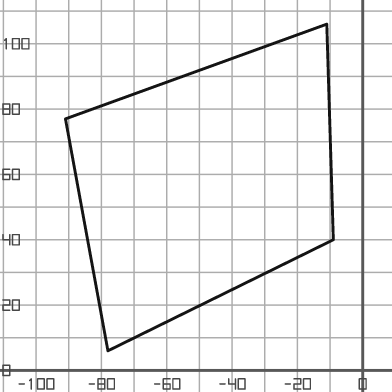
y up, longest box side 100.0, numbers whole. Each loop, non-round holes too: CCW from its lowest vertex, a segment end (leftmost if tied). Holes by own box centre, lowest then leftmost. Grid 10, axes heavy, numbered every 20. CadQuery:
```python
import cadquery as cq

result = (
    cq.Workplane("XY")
    .moveTo(-78.0, 6.0)
    .lineTo(-9.0, 40.0)
    .lineTo(-11.0, 106.0)
    .lineTo(-91.0, 77.0)
    .close()
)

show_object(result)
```